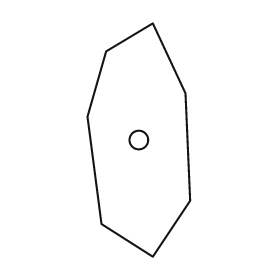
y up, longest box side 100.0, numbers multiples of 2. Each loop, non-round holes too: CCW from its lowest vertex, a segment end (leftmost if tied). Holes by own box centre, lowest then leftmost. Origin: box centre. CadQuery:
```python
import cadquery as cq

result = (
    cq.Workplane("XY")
    .moveTo(6.0, -50.0)
    .lineTo(22.0, -26.0)
    .lineTo(20.0, 20.0)
    .lineTo(6.0, 50.0)
    .lineTo(-14.0, 38.0)
    .lineTo(-22.0, 10.0)
    .lineTo(-16.0, -36.0)
    .close()
    .moveTo(0.0, 0.0)
    .circle(4.0)
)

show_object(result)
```